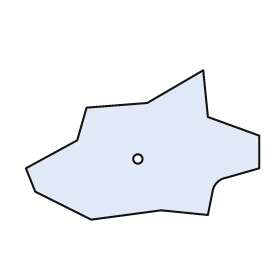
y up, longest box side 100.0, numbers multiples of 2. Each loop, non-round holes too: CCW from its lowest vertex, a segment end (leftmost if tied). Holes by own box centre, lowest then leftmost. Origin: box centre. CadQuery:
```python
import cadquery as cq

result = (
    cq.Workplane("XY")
    .moveTo(-22.0, -32.0)
    .lineTo(8.0, -28.0)
    .lineTo(28.0, -30.0)
    .lineTo(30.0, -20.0)
    .threePointArc((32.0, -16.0), (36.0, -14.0))
    .lineTo(50.0, -10.0)
    .lineTo(50.0, 4.0)
    .lineTo(28.0, 12.0)
    .lineTo(26.0, 32.0)
    .lineTo(2.0, 18.0)
    .lineTo(-24.0, 16.0)
    .lineTo(-28.0, 2.0)
    .lineTo(-50.0, -10.0)
    .lineTo(-46.0, -20.0)
    .close()
    .moveTo(-2.0, -6.0)
    .circle(2.0)
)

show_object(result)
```